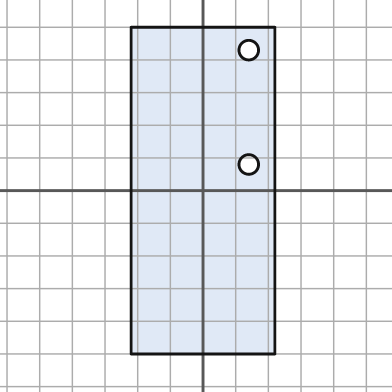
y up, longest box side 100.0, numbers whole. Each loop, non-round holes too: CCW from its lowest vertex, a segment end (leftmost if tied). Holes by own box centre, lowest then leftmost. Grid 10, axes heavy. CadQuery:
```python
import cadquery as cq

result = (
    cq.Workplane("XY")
    .moveTo(-22.0, -50.0)
    .lineTo(22.0, -50.0)
    .lineTo(22.0, 50.0)
    .lineTo(-22.0, 50.0)
    .close()
    .moveTo(14.0, 8.0)
    .circle(3.0)
    .moveTo(14.0, 43.0)
    .circle(3.0)
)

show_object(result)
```